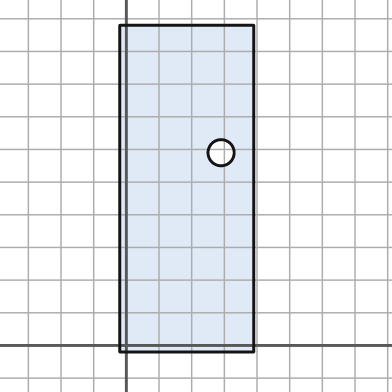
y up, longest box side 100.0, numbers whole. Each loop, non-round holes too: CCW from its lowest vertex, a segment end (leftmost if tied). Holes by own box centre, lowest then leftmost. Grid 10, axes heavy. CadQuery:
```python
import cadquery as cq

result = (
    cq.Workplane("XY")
    .moveTo(-2.0, -2.0)
    .lineTo(39.0, -2.0)
    .lineTo(39.0, 98.0)
    .lineTo(-2.0, 98.0)
    .close()
    .moveTo(29.0, 59.0)
    .circle(4.0)
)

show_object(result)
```